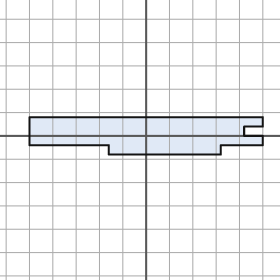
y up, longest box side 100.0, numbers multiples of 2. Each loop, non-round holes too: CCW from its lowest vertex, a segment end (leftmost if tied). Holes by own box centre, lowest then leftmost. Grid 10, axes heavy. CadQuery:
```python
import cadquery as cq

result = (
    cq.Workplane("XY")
    .moveTo(-16.0, -8.0)
    .lineTo(32.0, -8.0)
    .lineTo(32.0, -4.0)
    .lineTo(50.0, -4.0)
    .lineTo(50.0, 0.0)
    .lineTo(42.0, 0.0)
    .lineTo(42.0, 4.0)
    .lineTo(50.0, 4.0)
    .lineTo(50.0, 8.0)
    .lineTo(-50.0, 8.0)
    .lineTo(-50.0, -4.0)
    .lineTo(-16.0, -4.0)
    .close()
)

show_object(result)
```